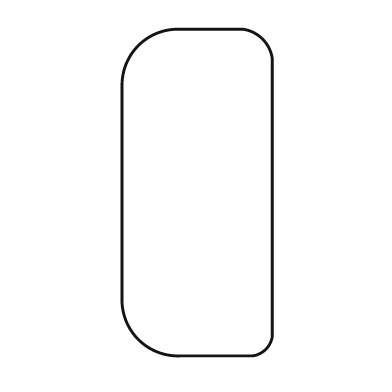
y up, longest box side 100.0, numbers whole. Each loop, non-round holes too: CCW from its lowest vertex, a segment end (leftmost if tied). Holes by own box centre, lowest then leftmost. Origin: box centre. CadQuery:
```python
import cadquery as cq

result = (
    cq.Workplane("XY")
    .moveTo(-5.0, -50.0)
    .lineTo(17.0, -50.0)
    .threePointArc((21.0, -48.0), (23.0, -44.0))
    .lineTo(23.0, 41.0)
    .threePointArc((20.0, 47.0), (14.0, 50.0))
    .lineTo(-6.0, 50.0)
    .threePointArc((-18.0, 45.0), (-23.0, 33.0))
    .lineTo(-23.0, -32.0)
    .threePointArc((-18.0, -45.0), (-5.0, -50.0))
    .close()
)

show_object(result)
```